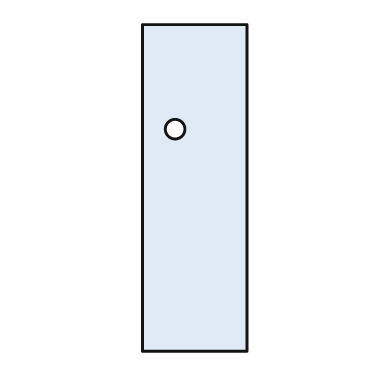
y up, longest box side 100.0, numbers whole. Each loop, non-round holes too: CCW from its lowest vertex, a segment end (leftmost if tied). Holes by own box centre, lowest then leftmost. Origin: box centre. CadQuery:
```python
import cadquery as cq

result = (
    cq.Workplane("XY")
    .moveTo(-16.0, -50.0)
    .lineTo(16.0, -50.0)
    .lineTo(16.0, 50.0)
    .lineTo(-16.0, 50.0)
    .close()
    .moveTo(-6.0, 18.0)
    .circle(3.0)
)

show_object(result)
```